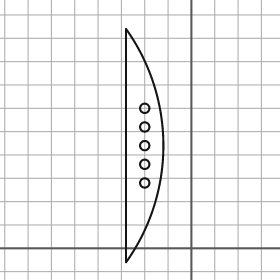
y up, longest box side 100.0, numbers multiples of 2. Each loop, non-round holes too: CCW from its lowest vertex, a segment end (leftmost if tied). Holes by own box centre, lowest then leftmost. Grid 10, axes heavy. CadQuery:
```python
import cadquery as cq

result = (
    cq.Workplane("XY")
    .moveTo(-28.0, -6.0)
    .threePointArc((-12.0, 44.0), (-28.0, 94.0))
    .close()
    .moveTo(-20.0, 28.0)
    .circle(2.0)
    .moveTo(-20.0, 36.0)
    .circle(2.0)
    .moveTo(-20.0, 44.0)
    .circle(2.0)
    .moveTo(-20.0, 52.0)
    .circle(2.0)
    .moveTo(-20.0, 60.0)
    .circle(2.0)
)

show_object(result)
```